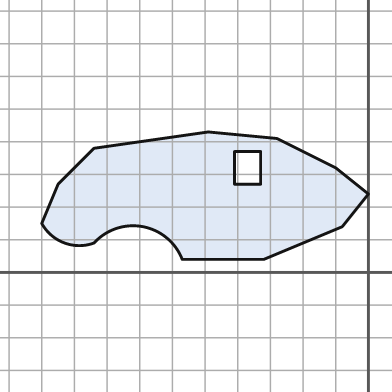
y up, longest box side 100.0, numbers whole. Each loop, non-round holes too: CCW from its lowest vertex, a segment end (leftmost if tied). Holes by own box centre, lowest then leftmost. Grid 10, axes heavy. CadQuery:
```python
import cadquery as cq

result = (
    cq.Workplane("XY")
    .moveTo(-57.0, 4.0)
    .lineTo(-32.0, 4.0)
    .lineTo(-8.0, 14.0)
    .lineTo(0.0, 24.0)
    .lineTo(-10.0, 32.0)
    .lineTo(-28.0, 41.0)
    .lineTo(-49.0, 43.0)
    .lineTo(-84.0, 38.0)
    .lineTo(-95.0, 27.0)
    .lineTo(-100.0, 15.0)
    .threePointArc((-93.0, 9.0), (-84.0, 9.0))
    .threePointArc((-69.0, 14.0), (-57.0, 4.0))
    .close()
    .moveTo(-41.0, 27.0)
    .lineTo(-33.0, 27.0)
    .lineTo(-33.0, 37.0)
    .lineTo(-41.0, 37.0)
    .close()
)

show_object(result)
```